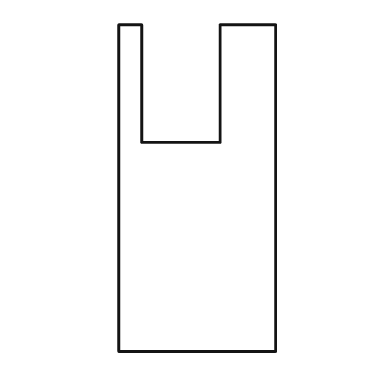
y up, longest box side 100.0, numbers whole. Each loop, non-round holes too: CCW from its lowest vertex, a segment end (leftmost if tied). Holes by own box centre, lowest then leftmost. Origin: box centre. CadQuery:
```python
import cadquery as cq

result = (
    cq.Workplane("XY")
    .moveTo(-24.0, -50.0)
    .lineTo(24.0, -50.0)
    .lineTo(24.0, 50.0)
    .lineTo(7.0, 50.0)
    .lineTo(7.0, 14.0)
    .lineTo(-17.0, 14.0)
    .lineTo(-17.0, 50.0)
    .lineTo(-24.0, 50.0)
    .close()
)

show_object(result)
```